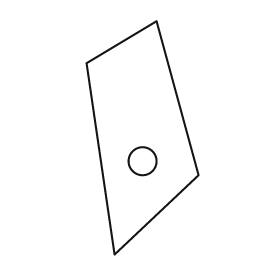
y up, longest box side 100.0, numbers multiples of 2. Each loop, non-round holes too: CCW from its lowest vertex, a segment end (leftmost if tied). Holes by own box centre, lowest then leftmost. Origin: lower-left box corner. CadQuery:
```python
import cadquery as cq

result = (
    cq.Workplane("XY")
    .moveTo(12.0, 0.0)
    .lineTo(48.0, 34.0)
    .lineTo(30.0, 100.0)
    .lineTo(0.0, 82.0)
    .close()
    .moveTo(24.0, 40.0)
    .circle(6.0)
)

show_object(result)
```